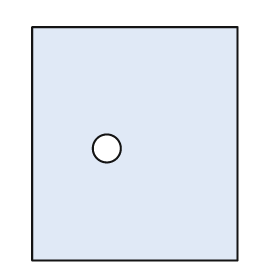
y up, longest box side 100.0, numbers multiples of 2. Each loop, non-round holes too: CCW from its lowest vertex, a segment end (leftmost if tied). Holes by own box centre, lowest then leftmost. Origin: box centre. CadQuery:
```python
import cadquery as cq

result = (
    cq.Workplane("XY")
    .moveTo(-44.0, -50.0)
    .lineTo(44.0, -50.0)
    .lineTo(44.0, 50.0)
    .lineTo(-44.0, 50.0)
    .close()
    .moveTo(-12.0, -2.0)
    .circle(6.0)
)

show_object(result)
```